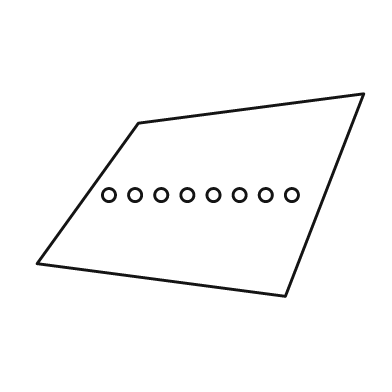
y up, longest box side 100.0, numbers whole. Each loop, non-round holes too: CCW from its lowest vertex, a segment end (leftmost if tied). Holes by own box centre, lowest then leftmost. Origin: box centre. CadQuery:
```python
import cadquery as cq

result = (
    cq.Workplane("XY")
    .moveTo(26.0, -31.0)
    .lineTo(50.0, 31.0)
    .lineTo(-19.0, 22.0)
    .lineTo(-50.0, -21.0)
    .close()
    .moveTo(-28.0, 0.0)
    .circle(2.0)
    .moveTo(-20.0, 0.0)
    .circle(2.0)
    .moveTo(-12.0, 0.0)
    .circle(2.0)
    .moveTo(-4.0, 0.0)
    .circle(2.0)
    .moveTo(4.0, 0.0)
    .circle(2.0)
    .moveTo(12.0, 0.0)
    .circle(2.0)
    .moveTo(20.0, 0.0)
    .circle(2.0)
    .moveTo(28.0, 0.0)
    .circle(2.0)
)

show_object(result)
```